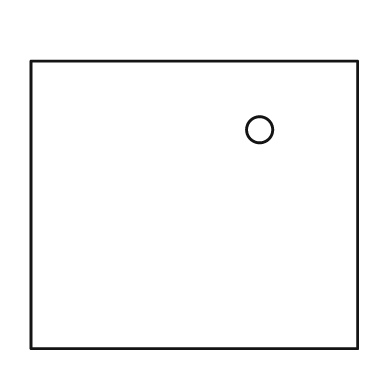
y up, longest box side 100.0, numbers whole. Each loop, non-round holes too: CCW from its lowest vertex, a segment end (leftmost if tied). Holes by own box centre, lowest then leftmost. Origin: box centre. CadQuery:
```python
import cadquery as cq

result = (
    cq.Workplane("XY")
    .moveTo(-50.0, -44.0)
    .lineTo(50.0, -44.0)
    .lineTo(50.0, 44.0)
    .lineTo(-50.0, 44.0)
    .close()
    .moveTo(20.0, 23.0)
    .circle(4.0)
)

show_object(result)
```